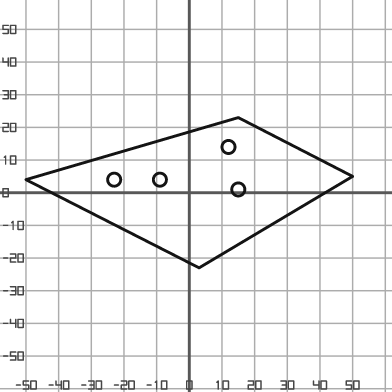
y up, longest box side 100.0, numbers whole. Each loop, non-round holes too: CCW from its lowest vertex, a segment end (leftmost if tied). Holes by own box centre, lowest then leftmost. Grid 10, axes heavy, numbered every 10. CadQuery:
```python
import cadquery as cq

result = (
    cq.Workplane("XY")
    .moveTo(3.0, -23.0)
    .lineTo(50.0, 5.0)
    .lineTo(15.0, 23.0)
    .lineTo(-50.0, 4.0)
    .close()
    .moveTo(15.0, 1.0)
    .circle(2.0)
    .moveTo(-23.0, 4.0)
    .circle(2.0)
    .moveTo(-9.0, 4.0)
    .circle(2.0)
    .moveTo(12.0, 14.0)
    .circle(2.0)
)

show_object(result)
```